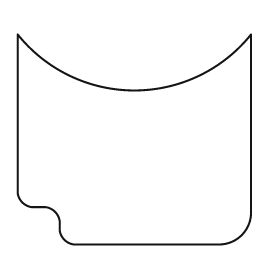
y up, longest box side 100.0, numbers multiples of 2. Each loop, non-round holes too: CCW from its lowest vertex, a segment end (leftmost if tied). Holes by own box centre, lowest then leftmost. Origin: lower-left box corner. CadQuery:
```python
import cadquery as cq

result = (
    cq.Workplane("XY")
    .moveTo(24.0, 0.0)
    .lineTo(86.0, 0.0)
    .threePointArc((96.0, 4.0), (100.0, 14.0))
    .lineTo(100.0, 90.0)
    .threePointArc((50.0, 66.0), (0.0, 90.0))
    .lineTo(0.0, 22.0)
    .threePointArc((2.0, 18.0), (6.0, 16.0))
    .lineTo(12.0, 16.0)
    .threePointArc((16.0, 14.0), (18.0, 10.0))
    .lineTo(18.0, 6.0)
    .threePointArc((20.0, 2.0), (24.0, 0.0))
    .close()
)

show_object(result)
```